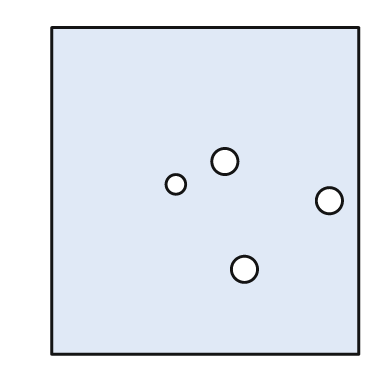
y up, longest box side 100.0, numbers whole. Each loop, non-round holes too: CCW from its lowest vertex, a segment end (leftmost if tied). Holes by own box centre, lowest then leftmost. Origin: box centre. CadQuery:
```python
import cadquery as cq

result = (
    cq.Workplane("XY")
    .moveTo(-47.0, -50.0)
    .lineTo(47.0, -50.0)
    .lineTo(47.0, 50.0)
    .lineTo(-47.0, 50.0)
    .close()
    .moveTo(12.0, -24.0)
    .circle(4.0)
    .moveTo(38.0, -3.0)
    .circle(4.0)
    .moveTo(-9.0, 2.0)
    .circle(3.0)
    .moveTo(6.0, 9.0)
    .circle(4.0)
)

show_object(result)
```